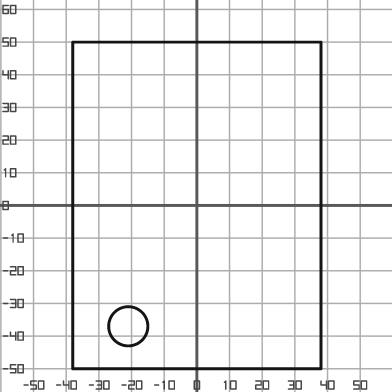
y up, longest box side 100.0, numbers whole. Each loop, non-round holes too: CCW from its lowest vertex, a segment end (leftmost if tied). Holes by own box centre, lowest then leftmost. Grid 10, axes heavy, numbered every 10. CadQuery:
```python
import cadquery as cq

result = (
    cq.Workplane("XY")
    .moveTo(-38.0, -50.0)
    .lineTo(38.0, -50.0)
    .lineTo(38.0, 50.0)
    .lineTo(-38.0, 50.0)
    .close()
    .moveTo(-21.0, -37.0)
    .circle(6.0)
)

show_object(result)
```